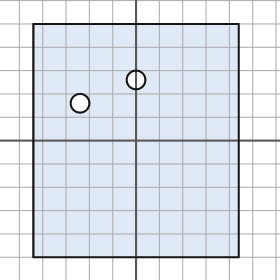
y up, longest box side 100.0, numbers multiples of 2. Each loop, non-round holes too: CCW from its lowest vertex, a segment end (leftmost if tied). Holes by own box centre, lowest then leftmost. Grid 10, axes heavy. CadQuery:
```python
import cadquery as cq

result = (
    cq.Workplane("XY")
    .moveTo(-44.0, -50.0)
    .lineTo(44.0, -50.0)
    .lineTo(44.0, 50.0)
    .lineTo(-44.0, 50.0)
    .close()
    .moveTo(-24.0, 16.0)
    .circle(4.0)
    .moveTo(0.0, 26.0)
    .circle(4.0)
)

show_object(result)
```